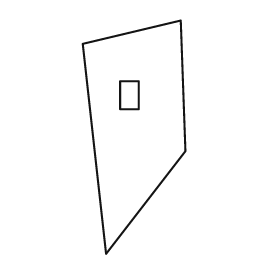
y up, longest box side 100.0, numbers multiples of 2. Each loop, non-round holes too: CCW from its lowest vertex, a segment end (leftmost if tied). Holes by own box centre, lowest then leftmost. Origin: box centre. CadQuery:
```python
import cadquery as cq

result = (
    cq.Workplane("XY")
    .moveTo(-12.0, -50.0)
    .lineTo(22.0, -6.0)
    .lineTo(20.0, 50.0)
    .lineTo(-22.0, 40.0)
    .close()
    .moveTo(-6.0, 12.0)
    .lineTo(2.0, 12.0)
    .lineTo(2.0, 24.0)
    .lineTo(-6.0, 24.0)
    .close()
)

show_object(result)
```